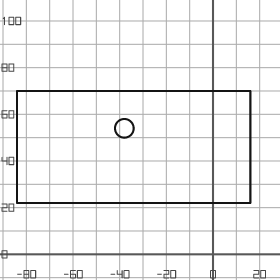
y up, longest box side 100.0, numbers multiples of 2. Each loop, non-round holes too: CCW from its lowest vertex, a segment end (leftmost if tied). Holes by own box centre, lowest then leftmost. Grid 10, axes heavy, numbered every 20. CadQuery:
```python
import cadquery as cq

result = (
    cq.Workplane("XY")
    .moveTo(-84.0, 22.0)
    .lineTo(16.0, 22.0)
    .lineTo(16.0, 70.0)
    .lineTo(-84.0, 70.0)
    .close()
    .moveTo(-38.0, 54.0)
    .circle(4.0)
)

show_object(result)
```